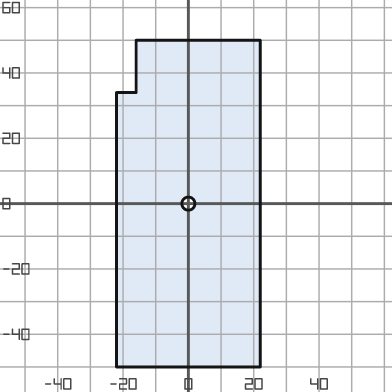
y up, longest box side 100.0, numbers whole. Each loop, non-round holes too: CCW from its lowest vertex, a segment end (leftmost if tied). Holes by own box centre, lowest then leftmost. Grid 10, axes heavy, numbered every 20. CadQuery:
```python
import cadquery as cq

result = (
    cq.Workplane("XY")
    .moveTo(-22.0, -50.0)
    .lineTo(22.0, -50.0)
    .lineTo(22.0, 50.0)
    .lineTo(-16.0, 50.0)
    .lineTo(-16.0, 34.0)
    .lineTo(-22.0, 34.0)
    .close()
    .moveTo(0.0, 0.0)
    .circle(2.0)
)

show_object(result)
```